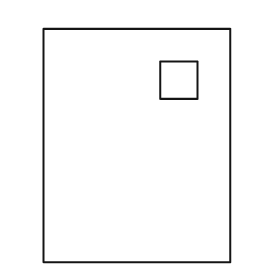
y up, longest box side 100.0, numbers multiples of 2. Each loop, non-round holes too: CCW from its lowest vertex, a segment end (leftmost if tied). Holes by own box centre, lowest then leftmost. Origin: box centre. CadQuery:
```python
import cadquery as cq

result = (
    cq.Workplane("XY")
    .moveTo(-40.0, -50.0)
    .lineTo(40.0, -50.0)
    .lineTo(40.0, 50.0)
    .lineTo(-40.0, 50.0)
    .close()
    .moveTo(10.0, 20.0)
    .lineTo(26.0, 20.0)
    .lineTo(26.0, 36.0)
    .lineTo(10.0, 36.0)
    .close()
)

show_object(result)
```